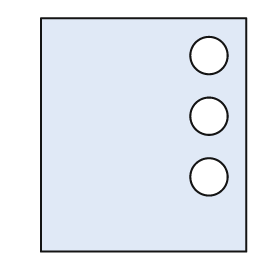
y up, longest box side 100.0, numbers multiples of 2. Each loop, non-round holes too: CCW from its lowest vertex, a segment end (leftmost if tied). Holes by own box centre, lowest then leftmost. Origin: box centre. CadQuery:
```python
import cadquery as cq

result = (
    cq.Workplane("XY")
    .moveTo(-44.0, -50.0)
    .lineTo(44.0, -50.0)
    .lineTo(44.0, 50.0)
    .lineTo(-44.0, 50.0)
    .close()
    .moveTo(28.0, -18.0)
    .circle(8.0)
    .moveTo(28.0, 8.0)
    .circle(8.0)
    .moveTo(28.0, 34.0)
    .circle(8.0)
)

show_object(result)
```